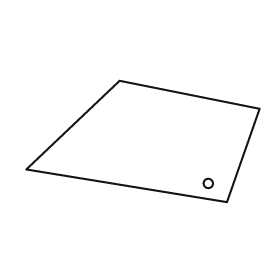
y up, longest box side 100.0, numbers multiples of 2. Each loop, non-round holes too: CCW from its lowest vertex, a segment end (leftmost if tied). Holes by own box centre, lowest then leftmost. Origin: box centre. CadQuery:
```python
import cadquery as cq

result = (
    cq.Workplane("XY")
    .moveTo(36.0, -26.0)
    .lineTo(50.0, 14.0)
    .lineTo(-10.0, 26.0)
    .lineTo(-50.0, -12.0)
    .close()
    .moveTo(28.0, -18.0)
    .circle(2.0)
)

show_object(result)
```